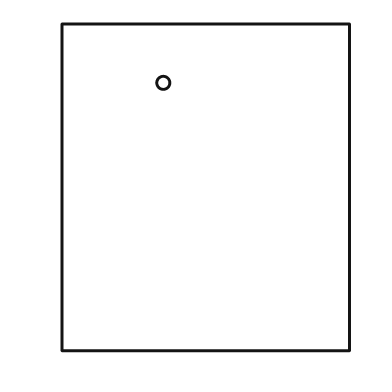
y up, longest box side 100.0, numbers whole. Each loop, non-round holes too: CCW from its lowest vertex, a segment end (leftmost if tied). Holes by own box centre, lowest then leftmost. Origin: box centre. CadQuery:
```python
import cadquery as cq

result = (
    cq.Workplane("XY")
    .moveTo(-44.0, -50.0)
    .lineTo(44.0, -50.0)
    .lineTo(44.0, 50.0)
    .lineTo(-44.0, 50.0)
    .close()
    .moveTo(-13.0, 32.0)
    .circle(2.0)
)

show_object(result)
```